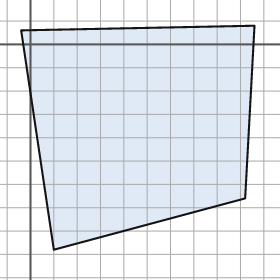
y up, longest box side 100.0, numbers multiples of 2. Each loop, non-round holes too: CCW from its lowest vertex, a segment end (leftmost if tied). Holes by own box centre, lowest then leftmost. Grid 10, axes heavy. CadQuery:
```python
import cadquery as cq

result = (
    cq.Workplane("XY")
    .moveTo(10.0, -88.0)
    .lineTo(92.0, -66.0)
    .lineTo(96.0, 8.0)
    .lineTo(-4.0, 6.0)
    .close()
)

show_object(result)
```